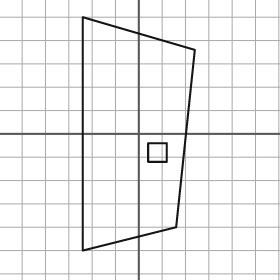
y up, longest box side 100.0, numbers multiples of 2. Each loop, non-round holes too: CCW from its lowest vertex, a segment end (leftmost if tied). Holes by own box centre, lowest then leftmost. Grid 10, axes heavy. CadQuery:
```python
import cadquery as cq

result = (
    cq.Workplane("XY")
    .moveTo(-24.0, -50.0)
    .lineTo(16.0, -40.0)
    .lineTo(24.0, 36.0)
    .lineTo(-24.0, 50.0)
    .close()
    .moveTo(4.0, -12.0)
    .lineTo(12.0, -12.0)
    .lineTo(12.0, -4.0)
    .lineTo(4.0, -4.0)
    .close()
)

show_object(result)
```